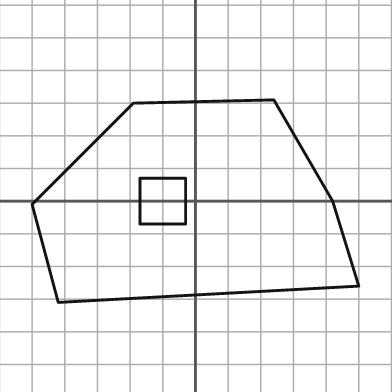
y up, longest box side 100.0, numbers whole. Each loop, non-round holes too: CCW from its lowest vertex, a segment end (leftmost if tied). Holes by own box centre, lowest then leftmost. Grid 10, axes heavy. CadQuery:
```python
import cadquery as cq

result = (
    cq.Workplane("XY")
    .moveTo(-42.0, -31.0)
    .lineTo(50.0, -26.0)
    .lineTo(42.0, 0.0)
    .lineTo(24.0, 31.0)
    .lineTo(-19.0, 30.0)
    .lineTo(-50.0, -1.0)
    .close()
    .moveTo(-17.0, -7.0)
    .lineTo(-3.0, -7.0)
    .lineTo(-3.0, 7.0)
    .lineTo(-17.0, 7.0)
    .close()
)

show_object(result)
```